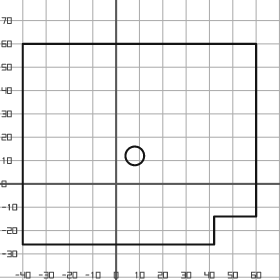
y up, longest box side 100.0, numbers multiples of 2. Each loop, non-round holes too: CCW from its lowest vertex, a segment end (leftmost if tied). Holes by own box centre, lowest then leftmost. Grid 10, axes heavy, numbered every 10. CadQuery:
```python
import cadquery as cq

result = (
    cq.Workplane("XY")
    .moveTo(-40.0, -26.0)
    .lineTo(42.0, -26.0)
    .lineTo(42.0, -14.0)
    .lineTo(60.0, -14.0)
    .lineTo(60.0, 60.0)
    .lineTo(-40.0, 60.0)
    .close()
    .moveTo(8.0, 12.0)
    .circle(4.0)
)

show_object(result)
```